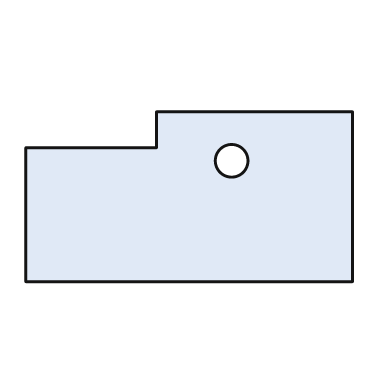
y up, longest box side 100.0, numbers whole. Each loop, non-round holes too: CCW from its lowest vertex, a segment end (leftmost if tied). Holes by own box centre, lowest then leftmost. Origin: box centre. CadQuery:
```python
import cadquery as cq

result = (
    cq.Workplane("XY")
    .moveTo(-50.0, -26.0)
    .lineTo(50.0, -26.0)
    .lineTo(50.0, 26.0)
    .lineTo(-10.0, 26.0)
    .lineTo(-10.0, 15.0)
    .lineTo(-50.0, 15.0)
    .close()
    .moveTo(13.0, 11.0)
    .circle(5.0)
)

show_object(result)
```